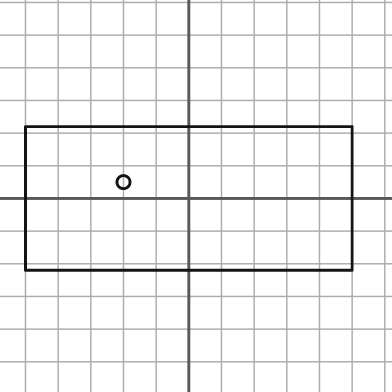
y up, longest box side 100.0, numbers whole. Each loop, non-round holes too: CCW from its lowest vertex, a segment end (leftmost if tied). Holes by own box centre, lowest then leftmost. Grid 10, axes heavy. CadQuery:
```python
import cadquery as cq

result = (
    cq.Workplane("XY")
    .moveTo(-50.0, -22.0)
    .lineTo(50.0, -22.0)
    .lineTo(50.0, 22.0)
    .lineTo(-50.0, 22.0)
    .close()
    .moveTo(-20.0, 5.0)
    .circle(2.0)
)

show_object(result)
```